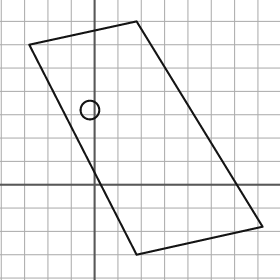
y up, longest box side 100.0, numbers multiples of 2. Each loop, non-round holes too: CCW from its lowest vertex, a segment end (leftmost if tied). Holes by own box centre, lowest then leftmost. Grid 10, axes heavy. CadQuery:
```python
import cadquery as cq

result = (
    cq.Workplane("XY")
    .moveTo(18.0, -30.0)
    .lineTo(72.0, -18.0)
    .lineTo(18.0, 70.0)
    .lineTo(-28.0, 60.0)
    .close()
    .moveTo(-2.0, 32.0)
    .circle(4.0)
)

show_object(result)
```